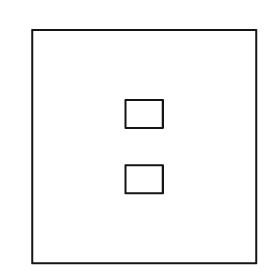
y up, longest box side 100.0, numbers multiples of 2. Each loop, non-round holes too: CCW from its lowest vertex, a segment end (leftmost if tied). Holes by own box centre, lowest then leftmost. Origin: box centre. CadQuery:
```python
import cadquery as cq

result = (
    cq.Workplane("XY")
    .moveTo(-48.0, -50.0)
    .lineTo(48.0, -50.0)
    .lineTo(48.0, 50.0)
    .lineTo(-48.0, 50.0)
    .close()
    .moveTo(-8.0, -20.0)
    .lineTo(8.0, -20.0)
    .lineTo(8.0, -8.0)
    .lineTo(-8.0, -8.0)
    .close()
    .moveTo(-8.0, 8.0)
    .lineTo(8.0, 8.0)
    .lineTo(8.0, 20.0)
    .lineTo(-8.0, 20.0)
    .close()
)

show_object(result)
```